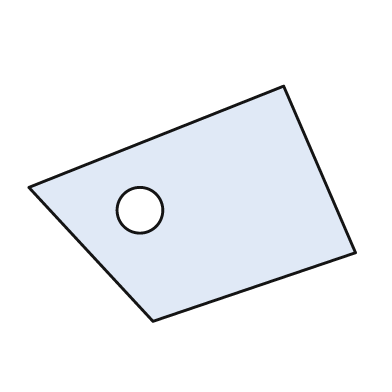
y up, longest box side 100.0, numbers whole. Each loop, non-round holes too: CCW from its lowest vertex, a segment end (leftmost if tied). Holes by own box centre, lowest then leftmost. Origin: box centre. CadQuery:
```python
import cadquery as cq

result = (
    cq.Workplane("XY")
    .moveTo(-12.0, -36.0)
    .lineTo(50.0, -15.0)
    .lineTo(28.0, 36.0)
    .lineTo(-50.0, 5.0)
    .close()
    .moveTo(-16.0, -2.0)
    .circle(7.0)
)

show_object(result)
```